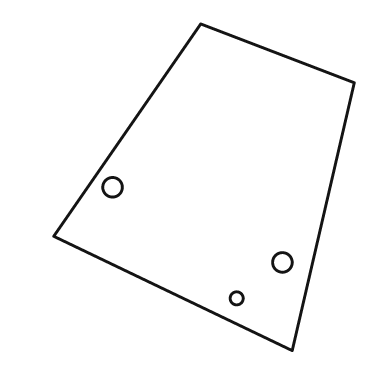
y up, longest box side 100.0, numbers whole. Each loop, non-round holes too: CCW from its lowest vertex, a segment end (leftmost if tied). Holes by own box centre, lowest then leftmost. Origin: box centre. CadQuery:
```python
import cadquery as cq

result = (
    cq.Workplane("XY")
    .moveTo(27.0, -50.0)
    .lineTo(46.0, 32.0)
    .lineTo(-1.0, 50.0)
    .lineTo(-46.0, -15.0)
    .close()
    .moveTo(10.0, -34.0)
    .circle(2.0)
    .moveTo(24.0, -23.0)
    .circle(3.0)
    .moveTo(-28.0, 0.0)
    .circle(3.0)
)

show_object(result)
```